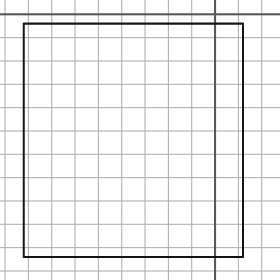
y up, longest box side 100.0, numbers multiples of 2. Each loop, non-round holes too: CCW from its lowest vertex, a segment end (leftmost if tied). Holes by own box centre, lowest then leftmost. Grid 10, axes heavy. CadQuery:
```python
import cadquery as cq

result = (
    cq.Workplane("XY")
    .moveTo(-82.0, -104.0)
    .lineTo(12.0, -104.0)
    .lineTo(12.0, -4.0)
    .lineTo(-82.0, -4.0)
    .close()
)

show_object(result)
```